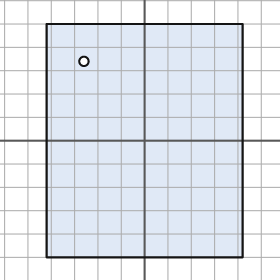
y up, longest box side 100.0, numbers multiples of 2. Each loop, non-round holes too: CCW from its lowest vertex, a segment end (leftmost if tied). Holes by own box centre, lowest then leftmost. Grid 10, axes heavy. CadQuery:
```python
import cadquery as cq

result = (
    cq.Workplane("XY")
    .moveTo(-42.0, -50.0)
    .lineTo(42.0, -50.0)
    .lineTo(42.0, 50.0)
    .lineTo(-42.0, 50.0)
    .close()
    .moveTo(-26.0, 34.0)
    .circle(2.0)
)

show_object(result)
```